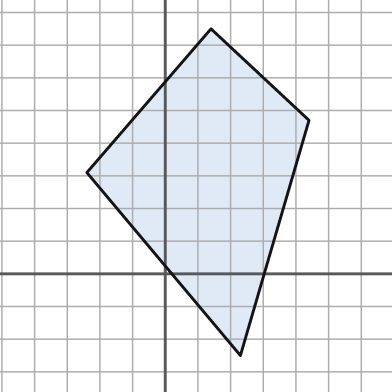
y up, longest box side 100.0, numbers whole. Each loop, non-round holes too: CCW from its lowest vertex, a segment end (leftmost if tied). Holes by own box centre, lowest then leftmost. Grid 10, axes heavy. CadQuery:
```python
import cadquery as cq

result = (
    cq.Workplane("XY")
    .moveTo(23.0, -25.0)
    .lineTo(44.0, 47.0)
    .lineTo(14.0, 75.0)
    .lineTo(-24.0, 31.0)
    .close()
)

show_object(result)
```